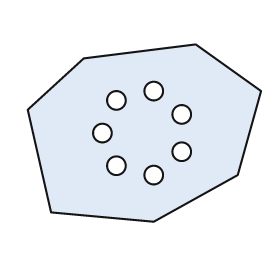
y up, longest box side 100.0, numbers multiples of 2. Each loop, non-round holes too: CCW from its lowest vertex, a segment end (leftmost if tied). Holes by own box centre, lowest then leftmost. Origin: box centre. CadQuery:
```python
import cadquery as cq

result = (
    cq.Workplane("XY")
    .moveTo(4.0, -38.0)
    .lineTo(40.0, -18.0)
    .lineTo(50.0, 18.0)
    .lineTo(22.0, 38.0)
    .lineTo(-26.0, 32.0)
    .lineTo(-50.0, 10.0)
    .lineTo(-40.0, -34.0)
    .close()
    .moveTo(4.0, -18.0)
    .circle(4.0)
    .moveTo(-12.0, -14.0)
    .circle(4.0)
    .moveTo(16.0, -8.0)
    .circle(4.0)
    .moveTo(-18.0, 0.0)
    .circle(4.0)
    .moveTo(16.0, 8.0)
    .circle(4.0)
    .moveTo(-12.0, 14.0)
    .circle(4.0)
    .moveTo(4.0, 18.0)
    .circle(4.0)
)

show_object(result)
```